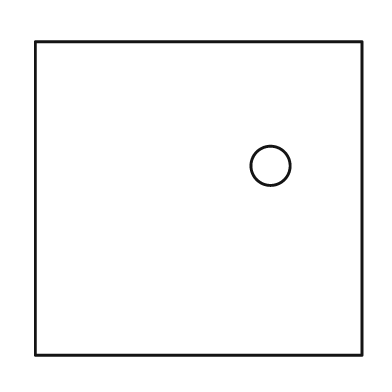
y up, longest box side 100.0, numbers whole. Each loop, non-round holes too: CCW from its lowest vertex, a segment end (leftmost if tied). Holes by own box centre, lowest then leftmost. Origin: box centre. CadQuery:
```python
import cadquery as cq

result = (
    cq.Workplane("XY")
    .moveTo(-50.0, -48.0)
    .lineTo(50.0, -48.0)
    .lineTo(50.0, 48.0)
    .lineTo(-50.0, 48.0)
    .close()
    .moveTo(22.0, 10.0)
    .circle(6.0)
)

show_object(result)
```